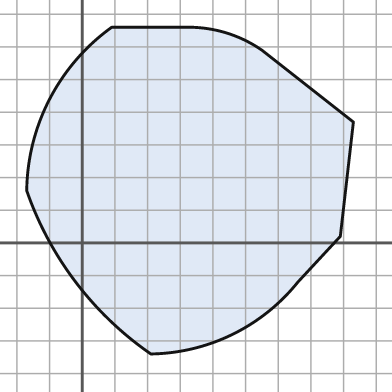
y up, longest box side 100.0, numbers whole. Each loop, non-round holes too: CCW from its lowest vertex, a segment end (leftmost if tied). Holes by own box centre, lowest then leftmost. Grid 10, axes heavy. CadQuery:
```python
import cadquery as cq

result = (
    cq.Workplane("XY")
    .moveTo(21.0, -34.0)
    .threePointArc((46.0, -28.0), (66.0, -12.0))
    .lineTo(79.0, 2.0)
    .lineTo(83.0, 37.0)
    .lineTo(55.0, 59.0)
    .threePointArc((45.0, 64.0), (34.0, 66.0))
    .lineTo(9.0, 66.0)
    .threePointArc((-10.0, 44.0), (-17.0, 16.0))
    .threePointArc((-2.0, -12.0), (21.0, -34.0))
    .close()
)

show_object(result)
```